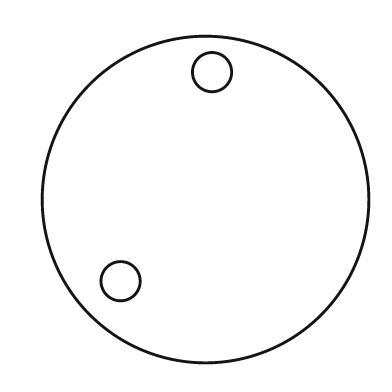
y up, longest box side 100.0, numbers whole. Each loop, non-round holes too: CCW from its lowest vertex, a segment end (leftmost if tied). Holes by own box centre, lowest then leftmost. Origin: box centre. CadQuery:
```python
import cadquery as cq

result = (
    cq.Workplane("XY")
    .moveTo(0.0, 0.0)
    .circle(50.0)
    .moveTo(-26.0, -25.0)
    .circle(6.0)
    .moveTo(2.0, 39.0)
    .circle(6.0)
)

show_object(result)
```